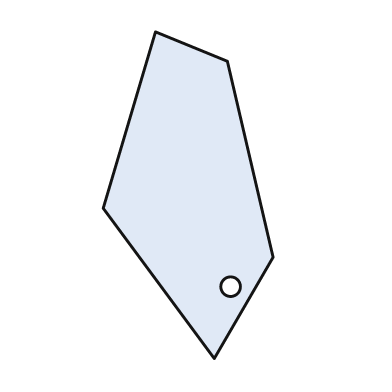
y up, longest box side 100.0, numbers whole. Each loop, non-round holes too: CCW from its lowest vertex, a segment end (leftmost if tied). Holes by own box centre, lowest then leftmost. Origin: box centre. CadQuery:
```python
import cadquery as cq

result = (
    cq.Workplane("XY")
    .moveTo(8.0, -50.0)
    .lineTo(26.0, -19.0)
    .lineTo(12.0, 41.0)
    .lineTo(-10.0, 50.0)
    .lineTo(-26.0, -4.0)
    .close()
    .moveTo(13.0, -28.0)
    .circle(3.0)
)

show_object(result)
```